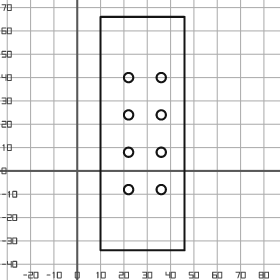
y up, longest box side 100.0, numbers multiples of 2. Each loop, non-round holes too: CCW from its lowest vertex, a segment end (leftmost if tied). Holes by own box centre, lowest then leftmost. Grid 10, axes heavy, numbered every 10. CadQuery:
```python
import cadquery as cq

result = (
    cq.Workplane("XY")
    .moveTo(10.0, -34.0)
    .lineTo(46.0, -34.0)
    .lineTo(46.0, 66.0)
    .lineTo(10.0, 66.0)
    .close()
    .moveTo(22.0, -8.0)
    .circle(2.0)
    .moveTo(36.0, -8.0)
    .circle(2.0)
    .moveTo(22.0, 8.0)
    .circle(2.0)
    .moveTo(36.0, 8.0)
    .circle(2.0)
    .moveTo(22.0, 24.0)
    .circle(2.0)
    .moveTo(36.0, 24.0)
    .circle(2.0)
    .moveTo(22.0, 40.0)
    .circle(2.0)
    .moveTo(36.0, 40.0)
    .circle(2.0)
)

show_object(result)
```